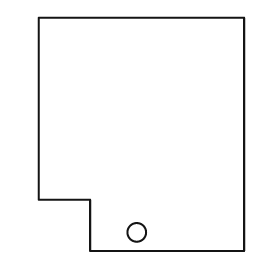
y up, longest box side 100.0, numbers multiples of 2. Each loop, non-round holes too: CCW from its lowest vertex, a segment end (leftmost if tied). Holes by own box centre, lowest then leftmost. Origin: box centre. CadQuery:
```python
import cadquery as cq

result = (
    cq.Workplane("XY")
    .moveTo(-22.0, -50.0)
    .lineTo(44.0, -50.0)
    .lineTo(44.0, 50.0)
    .lineTo(-44.0, 50.0)
    .lineTo(-44.0, -28.0)
    .lineTo(-22.0, -28.0)
    .close()
    .moveTo(-2.0, -42.0)
    .circle(4.0)
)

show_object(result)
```